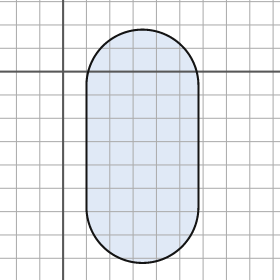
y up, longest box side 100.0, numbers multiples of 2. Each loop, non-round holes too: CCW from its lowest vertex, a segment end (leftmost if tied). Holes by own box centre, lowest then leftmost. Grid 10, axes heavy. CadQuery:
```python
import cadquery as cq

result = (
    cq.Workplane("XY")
    .moveTo(10.0, -58.0)
    .threePointArc((34.0, -82.0), (58.0, -58.0))
    .lineTo(58.0, -6.0)
    .threePointArc((34.0, 18.0), (10.0, -6.0))
    .close()
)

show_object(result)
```